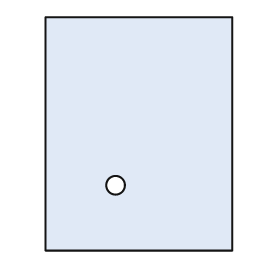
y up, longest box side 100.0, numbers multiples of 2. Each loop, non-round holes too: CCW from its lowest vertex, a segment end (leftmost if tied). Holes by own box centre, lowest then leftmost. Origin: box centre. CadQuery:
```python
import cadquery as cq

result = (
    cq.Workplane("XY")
    .moveTo(-40.0, -50.0)
    .lineTo(40.0, -50.0)
    .lineTo(40.0, 50.0)
    .lineTo(-40.0, 50.0)
    .close()
    .moveTo(-10.0, -22.0)
    .circle(4.0)
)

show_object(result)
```